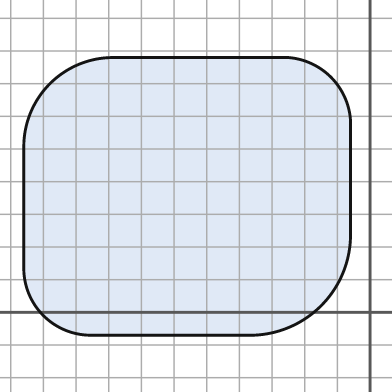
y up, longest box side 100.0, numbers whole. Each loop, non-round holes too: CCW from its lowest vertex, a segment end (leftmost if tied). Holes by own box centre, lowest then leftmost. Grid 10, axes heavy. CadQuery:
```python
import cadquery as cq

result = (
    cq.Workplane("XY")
    .moveTo(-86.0, -7.0)
    .lineTo(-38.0, -7.0)
    .threePointArc((-15.0, 2.0), (-6.0, 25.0))
    .lineTo(-6.0, 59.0)
    .threePointArc((-12.0, 72.0), (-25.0, 78.0))
    .lineTo(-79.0, 78.0)
    .threePointArc((-98.0, 70.0), (-106.0, 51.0))
    .lineTo(-106.0, 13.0)
    .threePointArc((-100.0, -1.0), (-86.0, -7.0))
    .close()
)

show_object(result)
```